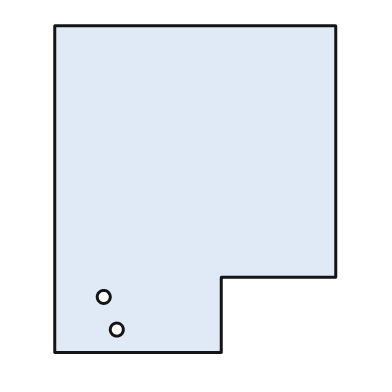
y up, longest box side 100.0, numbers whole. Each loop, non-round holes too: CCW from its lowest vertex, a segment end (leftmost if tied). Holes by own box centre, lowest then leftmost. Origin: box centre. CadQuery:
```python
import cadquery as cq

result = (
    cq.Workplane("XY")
    .moveTo(-43.0, -50.0)
    .lineTo(8.0, -50.0)
    .lineTo(8.0, -27.0)
    .lineTo(43.0, -27.0)
    .lineTo(43.0, 50.0)
    .lineTo(-43.0, 50.0)
    .close()
    .moveTo(-24.0, -43.0)
    .circle(2.0)
    .moveTo(-28.0, -33.0)
    .circle(2.0)
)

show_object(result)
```